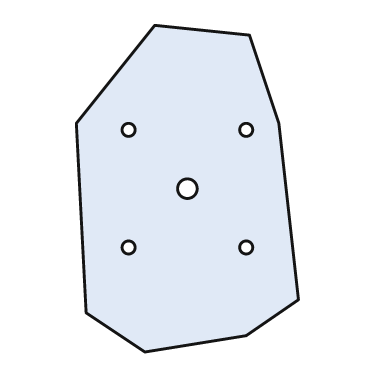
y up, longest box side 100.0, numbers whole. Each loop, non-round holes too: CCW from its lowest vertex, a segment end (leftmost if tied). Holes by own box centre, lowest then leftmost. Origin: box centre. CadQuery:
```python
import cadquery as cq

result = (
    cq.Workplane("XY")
    .moveTo(-13.0, -50.0)
    .lineTo(18.0, -45.0)
    .lineTo(34.0, -34.0)
    .lineTo(28.0, 20.0)
    .lineTo(19.0, 47.0)
    .lineTo(-10.0, 50.0)
    .lineTo(-34.0, 20.0)
    .lineTo(-31.0, -38.0)
    .close()
    .moveTo(-18.0, -18.0)
    .circle(2.0)
    .moveTo(18.0, -18.0)
    .circle(2.0)
    .moveTo(0.0, 0.0)
    .circle(3.0)
    .moveTo(-18.0, 18.0)
    .circle(2.0)
    .moveTo(18.0, 18.0)
    .circle(2.0)
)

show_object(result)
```